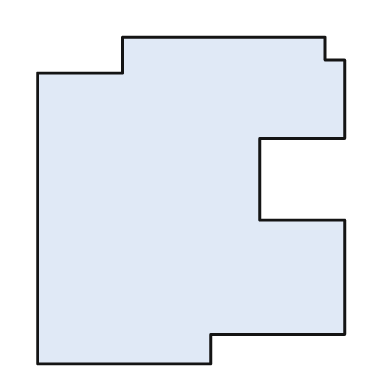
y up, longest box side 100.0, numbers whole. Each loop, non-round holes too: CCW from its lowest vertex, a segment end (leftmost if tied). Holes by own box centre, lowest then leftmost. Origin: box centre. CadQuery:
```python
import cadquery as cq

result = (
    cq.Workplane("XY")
    .moveTo(-47.0, -50.0)
    .lineTo(6.0, -50.0)
    .lineTo(6.0, -41.0)
    .lineTo(47.0, -41.0)
    .lineTo(47.0, -6.0)
    .lineTo(21.0, -6.0)
    .lineTo(21.0, 19.0)
    .lineTo(47.0, 19.0)
    .lineTo(47.0, 43.0)
    .lineTo(41.0, 43.0)
    .lineTo(41.0, 50.0)
    .lineTo(-21.0, 50.0)
    .lineTo(-21.0, 39.0)
    .lineTo(-47.0, 39.0)
    .close()
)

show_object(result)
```